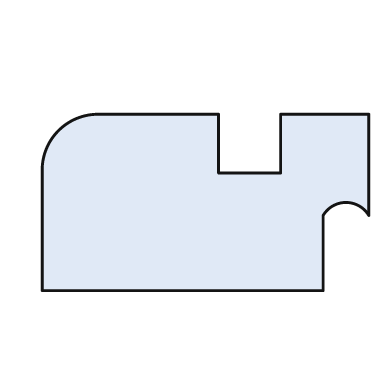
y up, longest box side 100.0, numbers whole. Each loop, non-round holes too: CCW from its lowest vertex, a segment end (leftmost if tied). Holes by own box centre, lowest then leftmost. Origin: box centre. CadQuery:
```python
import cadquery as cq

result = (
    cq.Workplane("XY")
    .moveTo(-50.0, -27.0)
    .lineTo(36.0, -27.0)
    .lineTo(36.0, -4.0)
    .threePointArc((43.0, 0.0), (50.0, -4.0))
    .lineTo(50.0, 27.0)
    .lineTo(23.0, 27.0)
    .lineTo(23.0, 9.0)
    .lineTo(4.0, 9.0)
    .lineTo(4.0, 27.0)
    .lineTo(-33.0, 27.0)
    .threePointArc((-45.0, 22.0), (-50.0, 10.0))
    .close()
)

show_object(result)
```